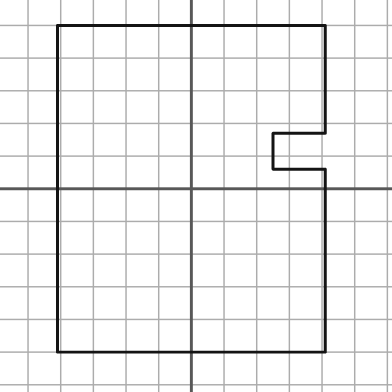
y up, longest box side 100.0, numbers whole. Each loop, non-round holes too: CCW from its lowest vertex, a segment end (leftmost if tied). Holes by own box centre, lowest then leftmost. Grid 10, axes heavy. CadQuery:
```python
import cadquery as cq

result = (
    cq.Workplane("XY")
    .moveTo(-41.0, -50.0)
    .lineTo(41.0, -50.0)
    .lineTo(41.0, 6.0)
    .lineTo(25.0, 6.0)
    .lineTo(25.0, 17.0)
    .lineTo(41.0, 17.0)
    .lineTo(41.0, 50.0)
    .lineTo(-41.0, 50.0)
    .close()
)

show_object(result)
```